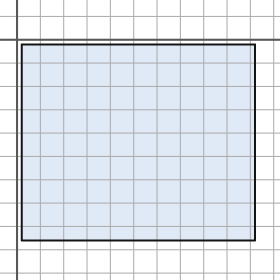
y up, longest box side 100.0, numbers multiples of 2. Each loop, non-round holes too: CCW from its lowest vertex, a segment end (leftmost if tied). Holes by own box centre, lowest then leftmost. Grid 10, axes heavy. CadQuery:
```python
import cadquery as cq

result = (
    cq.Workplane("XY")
    .moveTo(2.0, -86.0)
    .lineTo(102.0, -86.0)
    .lineTo(102.0, -2.0)
    .lineTo(2.0, -2.0)
    .close()
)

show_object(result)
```